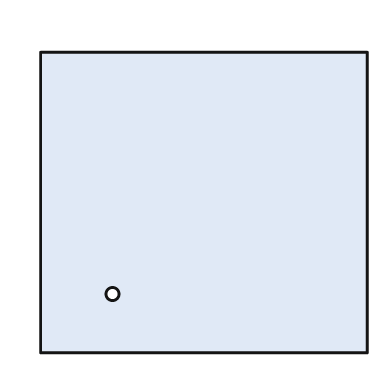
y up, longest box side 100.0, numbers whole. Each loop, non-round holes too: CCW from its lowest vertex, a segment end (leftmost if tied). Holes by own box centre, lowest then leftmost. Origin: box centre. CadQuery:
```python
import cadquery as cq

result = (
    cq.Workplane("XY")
    .moveTo(-50.0, -46.0)
    .lineTo(50.0, -46.0)
    .lineTo(50.0, 46.0)
    .lineTo(-50.0, 46.0)
    .close()
    .moveTo(-28.0, -28.0)
    .circle(2.0)
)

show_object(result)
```